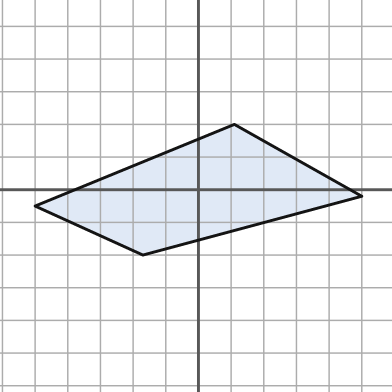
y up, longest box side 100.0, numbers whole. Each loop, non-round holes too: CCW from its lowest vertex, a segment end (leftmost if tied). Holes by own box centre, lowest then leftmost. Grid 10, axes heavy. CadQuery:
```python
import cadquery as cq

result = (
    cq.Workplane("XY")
    .moveTo(-17.0, -20.0)
    .lineTo(50.0, -2.0)
    .lineTo(11.0, 20.0)
    .lineTo(-50.0, -5.0)
    .close()
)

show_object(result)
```